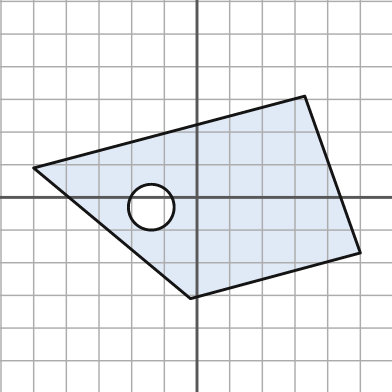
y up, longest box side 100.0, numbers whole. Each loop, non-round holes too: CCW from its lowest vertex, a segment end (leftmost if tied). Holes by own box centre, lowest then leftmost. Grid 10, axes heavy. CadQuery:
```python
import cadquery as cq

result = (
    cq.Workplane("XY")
    .moveTo(-2.0, -31.0)
    .lineTo(50.0, -17.0)
    .lineTo(33.0, 31.0)
    .lineTo(-50.0, 9.0)
    .close()
    .moveTo(-14.0, -3.0)
    .circle(7.0)
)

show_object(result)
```